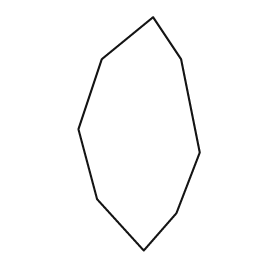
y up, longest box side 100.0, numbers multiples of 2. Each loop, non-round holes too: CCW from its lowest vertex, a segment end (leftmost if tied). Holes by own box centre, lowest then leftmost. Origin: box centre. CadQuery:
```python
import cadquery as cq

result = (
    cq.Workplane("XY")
    .moveTo(2.0, -50.0)
    .lineTo(16.0, -34.0)
    .lineTo(26.0, -8.0)
    .lineTo(18.0, 32.0)
    .lineTo(6.0, 50.0)
    .lineTo(-16.0, 32.0)
    .lineTo(-26.0, 2.0)
    .lineTo(-18.0, -28.0)
    .close()
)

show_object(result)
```